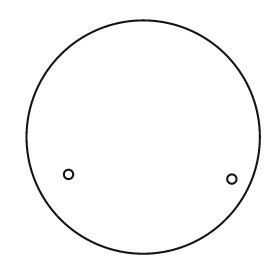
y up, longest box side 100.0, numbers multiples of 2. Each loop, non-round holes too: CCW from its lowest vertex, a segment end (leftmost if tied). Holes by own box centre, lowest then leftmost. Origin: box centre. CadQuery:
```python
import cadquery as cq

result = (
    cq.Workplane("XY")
    .moveTo(0.0, 0.0)
    .circle(50.0)
    .moveTo(38.0, -18.0)
    .circle(2.0)
    .moveTo(-32.0, -16.0)
    .circle(2.0)
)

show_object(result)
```